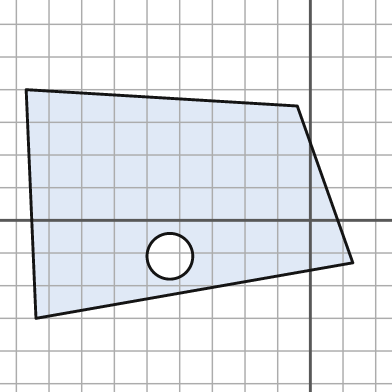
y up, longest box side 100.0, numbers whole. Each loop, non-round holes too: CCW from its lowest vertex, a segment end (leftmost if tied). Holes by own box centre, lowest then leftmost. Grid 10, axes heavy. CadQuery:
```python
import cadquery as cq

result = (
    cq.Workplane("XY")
    .moveTo(-84.0, -30.0)
    .lineTo(13.0, -13.0)
    .lineTo(-4.0, 35.0)
    .lineTo(-87.0, 40.0)
    .close()
    .moveTo(-43.0, -11.0)
    .circle(7.0)
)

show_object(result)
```